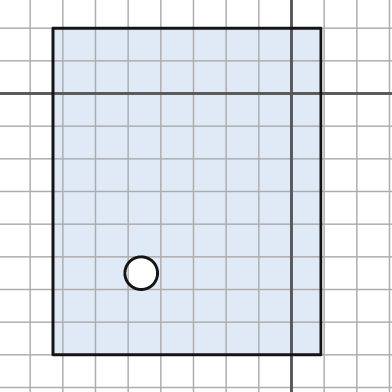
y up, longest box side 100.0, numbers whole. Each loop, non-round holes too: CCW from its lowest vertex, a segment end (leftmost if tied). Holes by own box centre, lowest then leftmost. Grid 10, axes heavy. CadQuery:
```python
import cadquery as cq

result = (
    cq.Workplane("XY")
    .moveTo(-73.0, -80.0)
    .lineTo(9.0, -80.0)
    .lineTo(9.0, 20.0)
    .lineTo(-73.0, 20.0)
    .close()
    .moveTo(-46.0, -55.0)
    .circle(5.0)
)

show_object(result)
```